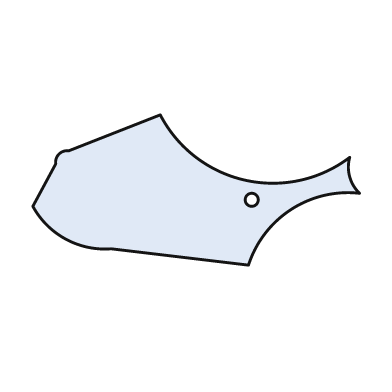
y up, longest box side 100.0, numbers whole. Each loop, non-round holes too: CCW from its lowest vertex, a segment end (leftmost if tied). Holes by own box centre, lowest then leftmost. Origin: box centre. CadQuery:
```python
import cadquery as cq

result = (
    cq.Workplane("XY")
    .moveTo(16.0, -23.0)
    .threePointArc((29.0, -6.0), (50.0, -1.0))
    .threePointArc((47.0, 4.0), (47.0, 10.0))
    .threePointArc((15.0, 3.0), (-11.0, 23.0))
    .lineTo(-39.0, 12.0)
    .threePointArc((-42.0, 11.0), (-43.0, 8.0))
    .lineTo(-50.0, -5.0)
    .threePointArc((-40.0, -15.0), (-26.0, -18.0))
    .close()
    .moveTo(17.0, -3.0)
    .circle(2.0)
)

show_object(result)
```